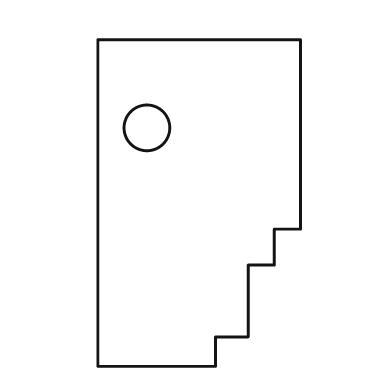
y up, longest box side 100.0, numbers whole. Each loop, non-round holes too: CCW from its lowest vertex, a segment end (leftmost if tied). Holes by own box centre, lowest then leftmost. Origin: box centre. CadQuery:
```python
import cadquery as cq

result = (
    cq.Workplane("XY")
    .moveTo(-31.0, -50.0)
    .lineTo(5.0, -50.0)
    .lineTo(5.0, -41.0)
    .lineTo(15.0, -41.0)
    .lineTo(15.0, -19.0)
    .lineTo(23.0, -19.0)
    .lineTo(23.0, -8.0)
    .lineTo(31.0, -8.0)
    .lineTo(31.0, 50.0)
    .lineTo(-31.0, 50.0)
    .close()
    .moveTo(-16.0, 23.0)
    .circle(7.0)
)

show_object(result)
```